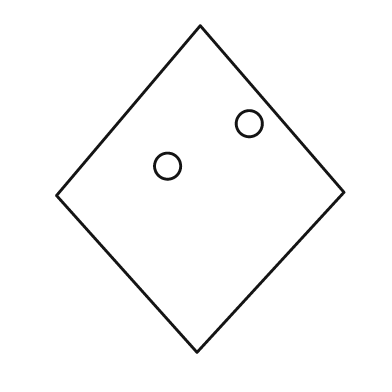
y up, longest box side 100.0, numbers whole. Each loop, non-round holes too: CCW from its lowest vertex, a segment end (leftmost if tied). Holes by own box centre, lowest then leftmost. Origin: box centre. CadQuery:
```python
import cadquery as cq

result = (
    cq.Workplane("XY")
    .moveTo(-1.0, -50.0)
    .lineTo(44.0, -1.0)
    .lineTo(0.0, 50.0)
    .lineTo(-44.0, -2.0)
    .close()
    .moveTo(-10.0, 7.0)
    .circle(4.0)
    .moveTo(15.0, 20.0)
    .circle(4.0)
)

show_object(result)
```